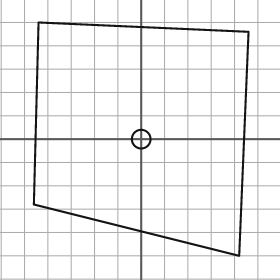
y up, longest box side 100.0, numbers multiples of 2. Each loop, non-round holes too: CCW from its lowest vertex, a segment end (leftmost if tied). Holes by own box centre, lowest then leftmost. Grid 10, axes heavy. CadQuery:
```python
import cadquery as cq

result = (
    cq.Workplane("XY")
    .moveTo(42.0, -50.0)
    .lineTo(46.0, 46.0)
    .lineTo(-44.0, 50.0)
    .lineTo(-46.0, -28.0)
    .close()
    .moveTo(0.0, 0.0)
    .circle(4.0)
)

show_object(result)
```